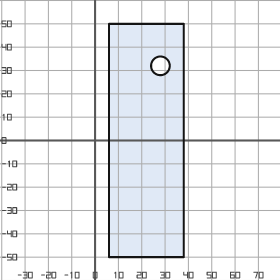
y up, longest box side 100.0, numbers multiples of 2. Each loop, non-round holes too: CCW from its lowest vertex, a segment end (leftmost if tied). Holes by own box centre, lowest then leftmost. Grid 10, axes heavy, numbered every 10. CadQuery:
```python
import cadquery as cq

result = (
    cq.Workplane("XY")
    .moveTo(6.0, -50.0)
    .lineTo(38.0, -50.0)
    .lineTo(38.0, 50.0)
    .lineTo(6.0, 50.0)
    .close()
    .moveTo(28.0, 32.0)
    .circle(4.0)
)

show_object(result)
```